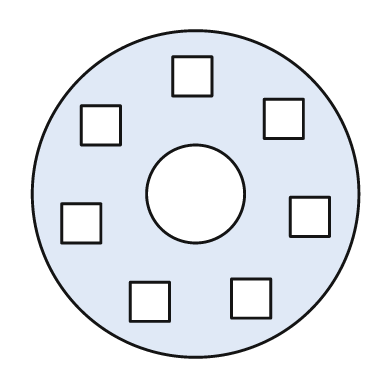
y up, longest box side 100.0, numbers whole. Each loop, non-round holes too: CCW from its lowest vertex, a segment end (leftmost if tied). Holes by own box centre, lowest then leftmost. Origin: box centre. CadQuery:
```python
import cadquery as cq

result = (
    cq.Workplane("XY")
    .moveTo(0.0, 0.0)
    .circle(50.0)
    .moveTo(-20.0, -39.0)
    .lineTo(-8.0, -39.0)
    .lineTo(-8.0, -27.0)
    .lineTo(-20.0, -27.0)
    .close()
    .moveTo(11.0, -38.0)
    .lineTo(23.0, -38.0)
    .lineTo(23.0, -26.0)
    .lineTo(11.0, -26.0)
    .close()
    .moveTo(-41.0, -15.0)
    .lineTo(-29.0, -15.0)
    .lineTo(-29.0, -3.0)
    .lineTo(-41.0, -3.0)
    .close()
    .moveTo(29.0, -13.0)
    .lineTo(41.0, -13.0)
    .lineTo(41.0, -1.0)
    .lineTo(29.0, -1.0)
    .close()
    .moveTo(0.0, 0.0)
    .circle(15.0)
    .moveTo(-35.0, 15.0)
    .lineTo(-23.0, 15.0)
    .lineTo(-23.0, 27.0)
    .lineTo(-35.0, 27.0)
    .close()
    .moveTo(21.0, 17.0)
    .lineTo(33.0, 17.0)
    .lineTo(33.0, 29.0)
    .lineTo(21.0, 29.0)
    .close()
    .moveTo(-7.0, 30.0)
    .lineTo(5.0, 30.0)
    .lineTo(5.0, 42.0)
    .lineTo(-7.0, 42.0)
    .close()
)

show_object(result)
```